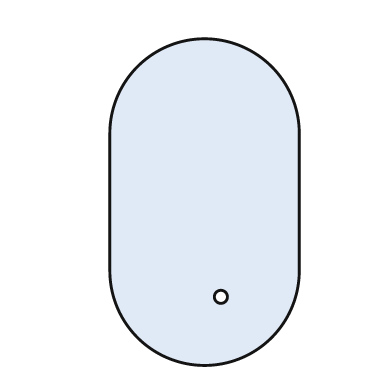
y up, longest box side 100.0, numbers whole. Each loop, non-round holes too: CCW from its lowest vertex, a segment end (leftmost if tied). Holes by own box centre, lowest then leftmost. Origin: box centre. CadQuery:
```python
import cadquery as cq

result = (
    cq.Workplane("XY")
    .moveTo(-29.0, -21.0)
    .threePointArc((0.0, -50.0), (29.0, -21.0))
    .lineTo(29.0, 21.0)
    .threePointArc((0.0, 50.0), (-29.0, 21.0))
    .close()
    .moveTo(5.0, -29.0)
    .circle(2.0)
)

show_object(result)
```